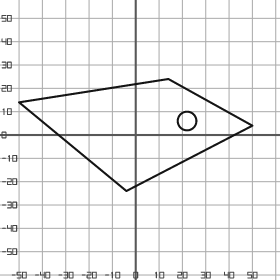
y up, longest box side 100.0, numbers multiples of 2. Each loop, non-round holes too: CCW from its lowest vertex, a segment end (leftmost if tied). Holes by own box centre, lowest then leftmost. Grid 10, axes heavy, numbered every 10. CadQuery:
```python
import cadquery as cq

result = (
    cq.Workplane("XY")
    .moveTo(-4.0, -24.0)
    .lineTo(50.0, 4.0)
    .lineTo(14.0, 24.0)
    .lineTo(-50.0, 14.0)
    .close()
    .moveTo(22.0, 6.0)
    .circle(4.0)
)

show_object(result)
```